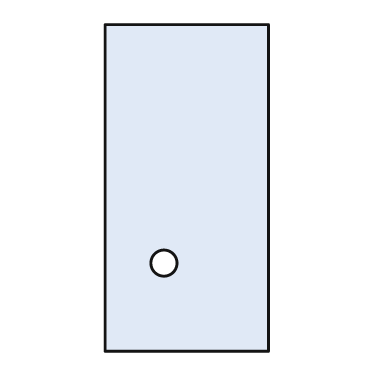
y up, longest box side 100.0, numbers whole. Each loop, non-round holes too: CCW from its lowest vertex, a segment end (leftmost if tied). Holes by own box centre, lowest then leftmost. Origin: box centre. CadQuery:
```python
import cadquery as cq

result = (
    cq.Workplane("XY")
    .moveTo(-25.0, -50.0)
    .lineTo(25.0, -50.0)
    .lineTo(25.0, 50.0)
    .lineTo(-25.0, 50.0)
    .close()
    .moveTo(-7.0, -23.0)
    .circle(4.0)
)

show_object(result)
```